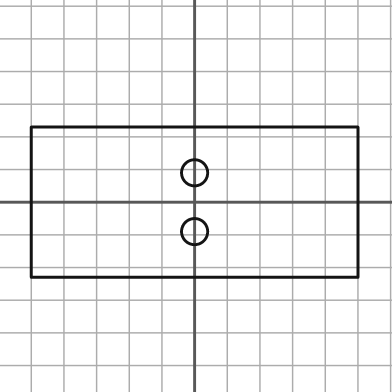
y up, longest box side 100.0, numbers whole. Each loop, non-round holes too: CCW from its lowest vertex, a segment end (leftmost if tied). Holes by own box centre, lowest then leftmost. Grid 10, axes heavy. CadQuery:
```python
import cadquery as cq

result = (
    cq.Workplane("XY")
    .moveTo(-50.0, -23.0)
    .lineTo(50.0, -23.0)
    .lineTo(50.0, 23.0)
    .lineTo(-50.0, 23.0)
    .close()
    .moveTo(0.0, -9.0)
    .circle(4.0)
    .moveTo(0.0, 9.0)
    .circle(4.0)
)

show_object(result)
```